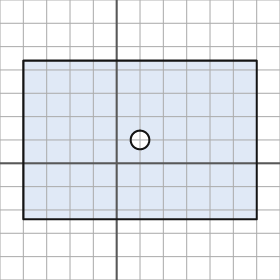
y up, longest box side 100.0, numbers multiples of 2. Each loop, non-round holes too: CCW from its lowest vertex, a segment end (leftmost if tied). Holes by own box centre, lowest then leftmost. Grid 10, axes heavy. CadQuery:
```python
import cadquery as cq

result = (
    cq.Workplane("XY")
    .moveTo(-40.0, -24.0)
    .lineTo(60.0, -24.0)
    .lineTo(60.0, 44.0)
    .lineTo(-40.0, 44.0)
    .close()
    .moveTo(10.0, 10.0)
    .circle(4.0)
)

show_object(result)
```